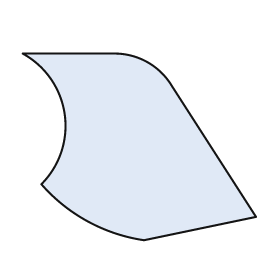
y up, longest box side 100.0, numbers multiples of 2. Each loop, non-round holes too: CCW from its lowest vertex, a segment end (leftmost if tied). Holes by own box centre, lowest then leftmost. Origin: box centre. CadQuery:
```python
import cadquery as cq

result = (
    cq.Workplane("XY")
    .moveTo(2.0, -40.0)
    .lineTo(50.0, -30.0)
    .lineTo(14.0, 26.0)
    .threePointArc((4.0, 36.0), (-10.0, 40.0))
    .lineTo(-50.0, 40.0)
    .threePointArc((-32.0, 14.0), (-42.0, -16.0))
    .threePointArc((-22.0, -32.0), (2.0, -40.0))
    .close()
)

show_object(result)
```